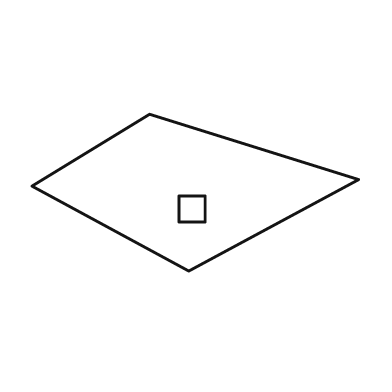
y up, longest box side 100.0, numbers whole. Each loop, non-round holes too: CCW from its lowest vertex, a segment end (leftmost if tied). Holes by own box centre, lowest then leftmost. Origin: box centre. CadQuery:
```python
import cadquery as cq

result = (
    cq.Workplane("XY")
    .moveTo(-2.0, -24.0)
    .lineTo(50.0, 4.0)
    .lineTo(-14.0, 24.0)
    .lineTo(-50.0, 2.0)
    .close()
    .moveTo(-5.0, -9.0)
    .lineTo(3.0, -9.0)
    .lineTo(3.0, -1.0)
    .lineTo(-5.0, -1.0)
    .close()
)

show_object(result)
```